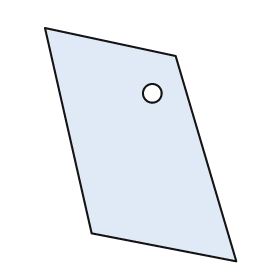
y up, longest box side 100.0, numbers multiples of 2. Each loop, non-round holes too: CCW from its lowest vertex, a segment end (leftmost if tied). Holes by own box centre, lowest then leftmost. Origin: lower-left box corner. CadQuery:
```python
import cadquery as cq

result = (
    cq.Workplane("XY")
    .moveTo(82.0, 0.0)
    .lineTo(56.0, 88.0)
    .lineTo(0.0, 100.0)
    .lineTo(20.0, 12.0)
    .close()
    .moveTo(46.0, 72.0)
    .circle(4.0)
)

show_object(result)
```